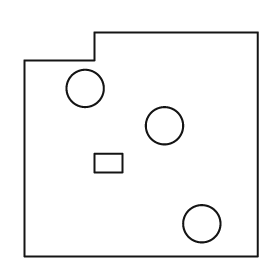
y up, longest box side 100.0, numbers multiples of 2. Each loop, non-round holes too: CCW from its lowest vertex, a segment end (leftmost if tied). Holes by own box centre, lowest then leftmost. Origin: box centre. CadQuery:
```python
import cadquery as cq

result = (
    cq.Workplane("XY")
    .moveTo(-50.0, -48.0)
    .lineTo(50.0, -48.0)
    .lineTo(50.0, 48.0)
    .lineTo(-20.0, 48.0)
    .lineTo(-20.0, 36.0)
    .lineTo(-50.0, 36.0)
    .close()
    .moveTo(26.0, -34.0)
    .circle(8.0)
    .moveTo(-20.0, -12.0)
    .lineTo(-8.0, -12.0)
    .lineTo(-8.0, -4.0)
    .lineTo(-20.0, -4.0)
    .close()
    .moveTo(10.0, 8.0)
    .circle(8.0)
    .moveTo(-24.0, 24.0)
    .circle(8.0)
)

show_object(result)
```